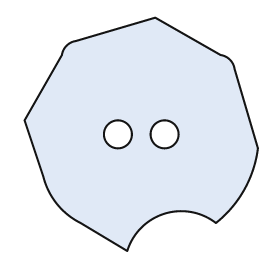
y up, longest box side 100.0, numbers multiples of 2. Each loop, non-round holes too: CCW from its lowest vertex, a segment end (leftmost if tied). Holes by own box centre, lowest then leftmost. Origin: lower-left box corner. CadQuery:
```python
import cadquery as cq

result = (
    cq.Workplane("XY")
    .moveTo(44.0, 0.0)
    .threePointArc((60.0, 16.0), (82.0, 12.0))
    .threePointArc((94.0, 26.0), (100.0, 44.0))
    .lineTo(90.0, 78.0)
    .threePointArc((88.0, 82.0), (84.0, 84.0))
    .lineTo(56.0, 100.0)
    .lineTo(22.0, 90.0)
    .threePointArc((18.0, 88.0), (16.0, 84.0))
    .lineTo(0.0, 56.0)
    .lineTo(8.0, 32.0)
    .threePointArc((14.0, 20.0), (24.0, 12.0))
    .close()
    .moveTo(40.0, 50.0)
    .circle(6.0)
    .moveTo(60.0, 50.0)
    .circle(6.0)
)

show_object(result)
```